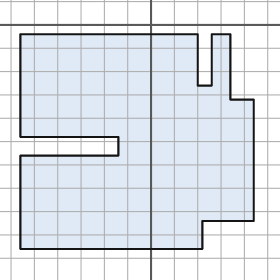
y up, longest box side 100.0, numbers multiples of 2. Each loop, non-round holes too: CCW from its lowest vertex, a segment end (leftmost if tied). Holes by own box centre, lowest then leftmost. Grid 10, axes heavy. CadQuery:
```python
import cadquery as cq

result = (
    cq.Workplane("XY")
    .moveTo(-56.0, -96.0)
    .lineTo(22.0, -96.0)
    .lineTo(22.0, -84.0)
    .lineTo(44.0, -84.0)
    .lineTo(44.0, -32.0)
    .lineTo(34.0, -32.0)
    .lineTo(34.0, -4.0)
    .lineTo(26.0, -4.0)
    .lineTo(26.0, -26.0)
    .lineTo(20.0, -26.0)
    .lineTo(20.0, -4.0)
    .lineTo(-56.0, -4.0)
    .lineTo(-56.0, -48.0)
    .lineTo(-14.0, -48.0)
    .lineTo(-14.0, -56.0)
    .lineTo(-56.0, -56.0)
    .close()
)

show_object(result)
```